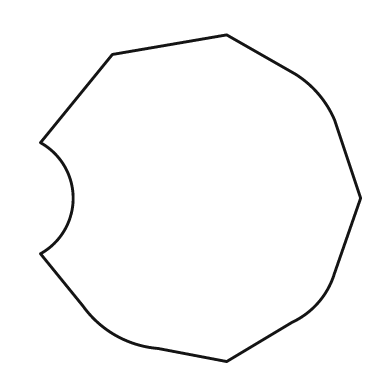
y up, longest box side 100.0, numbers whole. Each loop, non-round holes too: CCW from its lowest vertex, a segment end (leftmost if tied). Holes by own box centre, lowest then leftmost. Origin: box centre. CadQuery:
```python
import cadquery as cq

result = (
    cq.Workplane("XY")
    .moveTo(8.0, -50.0)
    .lineTo(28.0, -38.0)
    .threePointArc((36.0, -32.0), (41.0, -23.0))
    .lineTo(49.0, 0.0)
    .lineTo(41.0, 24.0)
    .threePointArc((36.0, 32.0), (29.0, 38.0))
    .lineTo(8.0, 50.0)
    .lineTo(-27.0, 44.0)
    .lineTo(-49.0, 17.0)
    .threePointArc((-39.0, 0.0), (-49.0, -17.0))
    .lineTo(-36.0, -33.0)
    .threePointArc((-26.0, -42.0), (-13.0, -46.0))
    .close()
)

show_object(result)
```